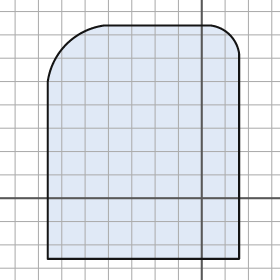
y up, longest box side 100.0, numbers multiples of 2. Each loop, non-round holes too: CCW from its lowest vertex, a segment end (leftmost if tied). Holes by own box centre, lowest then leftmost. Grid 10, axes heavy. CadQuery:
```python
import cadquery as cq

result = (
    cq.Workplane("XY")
    .moveTo(-66.0, -26.0)
    .lineTo(16.0, -26.0)
    .lineTo(16.0, 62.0)
    .threePointArc((12.0, 70.0), (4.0, 74.0))
    .lineTo(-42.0, 74.0)
    .threePointArc((-58.0, 66.0), (-66.0, 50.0))
    .close()
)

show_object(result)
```